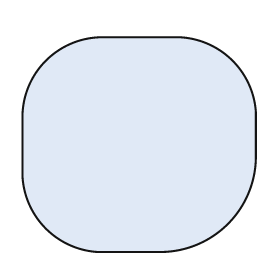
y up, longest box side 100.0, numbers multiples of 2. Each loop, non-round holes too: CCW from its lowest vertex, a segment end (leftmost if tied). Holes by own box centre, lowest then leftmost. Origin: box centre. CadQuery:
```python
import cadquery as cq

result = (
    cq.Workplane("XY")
    .moveTo(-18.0, -46.0)
    .lineTo(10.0, -46.0)
    .threePointArc((38.0, -34.0), (50.0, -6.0))
    .lineTo(50.0, 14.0)
    .threePointArc((40.0, 36.0), (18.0, 46.0))
    .lineTo(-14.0, 46.0)
    .threePointArc((-40.0, 36.0), (-50.0, 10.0))
    .lineTo(-50.0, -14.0)
    .threePointArc((-40.0, -36.0), (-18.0, -46.0))
    .close()
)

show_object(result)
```